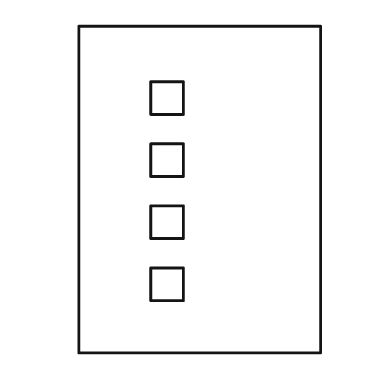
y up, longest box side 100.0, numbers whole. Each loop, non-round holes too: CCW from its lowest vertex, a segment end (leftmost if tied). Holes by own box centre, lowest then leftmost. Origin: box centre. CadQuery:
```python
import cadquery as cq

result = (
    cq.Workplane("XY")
    .moveTo(-37.0, -50.0)
    .lineTo(37.0, -50.0)
    .lineTo(37.0, 50.0)
    .lineTo(-37.0, 50.0)
    .close()
    .moveTo(-15.0, -34.0)
    .lineTo(-5.0, -34.0)
    .lineTo(-5.0, -24.0)
    .lineTo(-15.0, -24.0)
    .close()
    .moveTo(-15.0, -15.0)
    .lineTo(-5.0, -15.0)
    .lineTo(-5.0, -5.0)
    .lineTo(-15.0, -5.0)
    .close()
    .moveTo(-15.0, 4.0)
    .lineTo(-5.0, 4.0)
    .lineTo(-5.0, 14.0)
    .lineTo(-15.0, 14.0)
    .close()
    .moveTo(-15.0, 23.0)
    .lineTo(-5.0, 23.0)
    .lineTo(-5.0, 33.0)
    .lineTo(-15.0, 33.0)
    .close()
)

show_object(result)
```